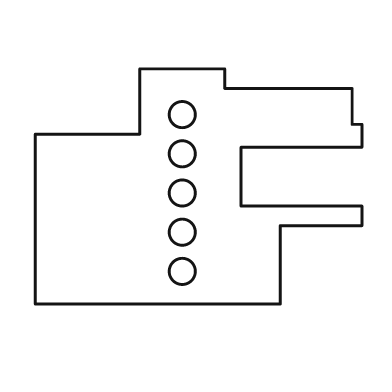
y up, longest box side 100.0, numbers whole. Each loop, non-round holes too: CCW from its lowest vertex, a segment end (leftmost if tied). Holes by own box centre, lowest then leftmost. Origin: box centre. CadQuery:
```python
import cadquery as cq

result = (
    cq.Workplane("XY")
    .moveTo(-50.0, -36.0)
    .lineTo(25.0, -36.0)
    .lineTo(25.0, -12.0)
    .lineTo(50.0, -12.0)
    .lineTo(50.0, -6.0)
    .lineTo(13.0, -6.0)
    .lineTo(13.0, 12.0)
    .lineTo(50.0, 12.0)
    .lineTo(50.0, 19.0)
    .lineTo(47.0, 19.0)
    .lineTo(47.0, 30.0)
    .lineTo(8.0, 30.0)
    .lineTo(8.0, 36.0)
    .lineTo(-18.0, 36.0)
    .lineTo(-18.0, 16.0)
    .lineTo(-50.0, 16.0)
    .close()
    .moveTo(-5.0, -26.0)
    .circle(4.0)
    .moveTo(-5.0, -14.0)
    .circle(4.0)
    .moveTo(-5.0, -2.0)
    .circle(4.0)
    .moveTo(-5.0, 10.0)
    .circle(4.0)
    .moveTo(-5.0, 22.0)
    .circle(4.0)
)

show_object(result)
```